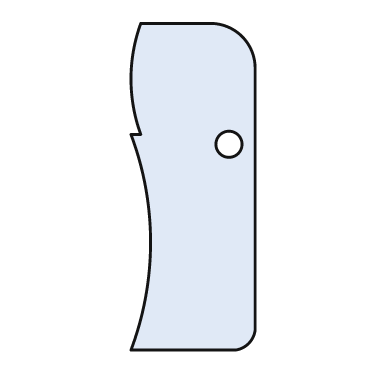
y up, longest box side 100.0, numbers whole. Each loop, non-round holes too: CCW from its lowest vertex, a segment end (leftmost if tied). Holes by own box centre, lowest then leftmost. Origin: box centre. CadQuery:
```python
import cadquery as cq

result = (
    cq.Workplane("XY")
    .moveTo(-19.0, -50.0)
    .lineTo(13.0, -50.0)
    .threePointArc((17.0, -48.0), (19.0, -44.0))
    .lineTo(19.0, 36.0)
    .threePointArc((15.0, 46.0), (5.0, 50.0))
    .lineTo(-16.0, 50.0)
    .threePointArc((-19.0, 33.0), (-16.0, 16.0))
    .lineTo(-19.0, 16.0)
    .threePointArc((-13.0, -17.0), (-19.0, -50.0))
    .close()
    .moveTo(11.0, 13.0)
    .circle(4.0)
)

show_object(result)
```